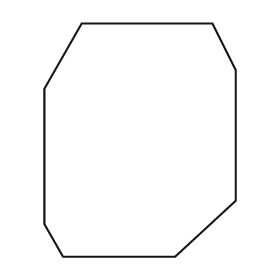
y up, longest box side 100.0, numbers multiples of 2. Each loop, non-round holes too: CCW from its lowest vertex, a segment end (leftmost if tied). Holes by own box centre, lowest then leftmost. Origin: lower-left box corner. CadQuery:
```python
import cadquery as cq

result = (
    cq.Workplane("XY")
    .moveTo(8.0, 0.0)
    .lineTo(56.0, 0.0)
    .lineTo(82.0, 24.0)
    .lineTo(82.0, 80.0)
    .lineTo(72.0, 100.0)
    .lineTo(16.0, 100.0)
    .lineTo(0.0, 72.0)
    .lineTo(0.0, 14.0)
    .close()
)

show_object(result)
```